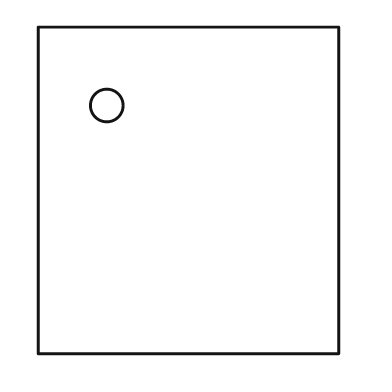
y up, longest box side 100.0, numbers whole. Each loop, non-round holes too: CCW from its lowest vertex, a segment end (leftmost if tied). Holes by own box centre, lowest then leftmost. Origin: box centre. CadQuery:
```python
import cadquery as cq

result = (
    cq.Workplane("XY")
    .moveTo(-46.0, -50.0)
    .lineTo(46.0, -50.0)
    .lineTo(46.0, 50.0)
    .lineTo(-46.0, 50.0)
    .close()
    .moveTo(-25.0, 26.0)
    .circle(5.0)
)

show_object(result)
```